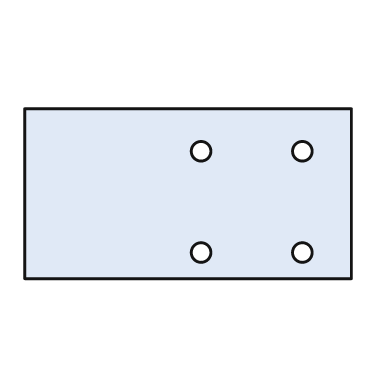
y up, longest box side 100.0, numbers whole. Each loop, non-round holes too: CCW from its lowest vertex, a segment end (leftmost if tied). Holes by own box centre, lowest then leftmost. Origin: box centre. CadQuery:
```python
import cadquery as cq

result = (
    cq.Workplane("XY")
    .moveTo(-50.0, -26.0)
    .lineTo(50.0, -26.0)
    .lineTo(50.0, 26.0)
    .lineTo(-50.0, 26.0)
    .close()
    .moveTo(4.0, -18.0)
    .circle(3.0)
    .moveTo(35.0, -18.0)
    .circle(3.0)
    .moveTo(4.0, 13.0)
    .circle(3.0)
    .moveTo(35.0, 13.0)
    .circle(3.0)
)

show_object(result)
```